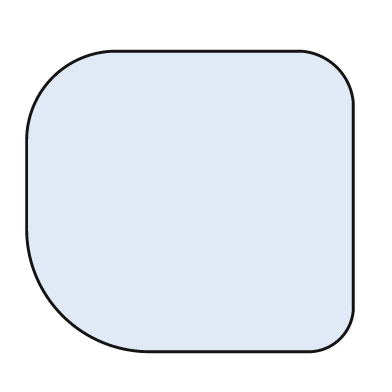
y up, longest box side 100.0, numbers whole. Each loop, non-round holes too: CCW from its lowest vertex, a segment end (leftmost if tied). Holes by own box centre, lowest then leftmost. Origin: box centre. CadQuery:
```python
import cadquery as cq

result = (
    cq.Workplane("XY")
    .moveTo(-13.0, -46.0)
    .lineTo(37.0, -46.0)
    .threePointArc((46.0, -42.0), (50.0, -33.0))
    .lineTo(50.0, 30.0)
    .threePointArc((45.0, 41.0), (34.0, 46.0))
    .lineTo(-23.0, 46.0)
    .threePointArc((-42.0, 38.0), (-50.0, 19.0))
    .lineTo(-50.0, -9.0)
    .threePointArc((-39.0, -35.0), (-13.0, -46.0))
    .close()
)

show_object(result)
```